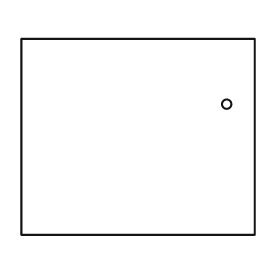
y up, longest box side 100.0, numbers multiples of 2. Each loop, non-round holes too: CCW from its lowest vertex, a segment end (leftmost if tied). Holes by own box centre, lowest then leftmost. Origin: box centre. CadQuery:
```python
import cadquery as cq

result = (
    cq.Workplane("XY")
    .moveTo(-50.0, -42.0)
    .lineTo(50.0, -42.0)
    .lineTo(50.0, 42.0)
    .lineTo(-50.0, 42.0)
    .close()
    .moveTo(38.0, 14.0)
    .circle(2.0)
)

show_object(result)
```